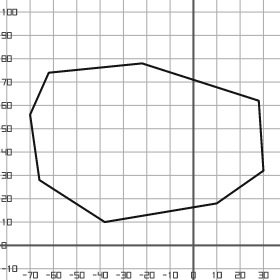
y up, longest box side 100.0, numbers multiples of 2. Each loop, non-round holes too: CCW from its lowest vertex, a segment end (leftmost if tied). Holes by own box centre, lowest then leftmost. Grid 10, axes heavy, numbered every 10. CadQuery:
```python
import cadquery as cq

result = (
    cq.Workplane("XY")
    .moveTo(-38.0, 10.0)
    .lineTo(10.0, 18.0)
    .lineTo(30.0, 32.0)
    .lineTo(28.0, 62.0)
    .lineTo(-22.0, 78.0)
    .lineTo(-62.0, 74.0)
    .lineTo(-70.0, 56.0)
    .lineTo(-66.0, 28.0)
    .close()
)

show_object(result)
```